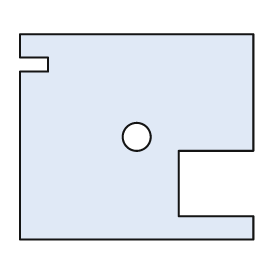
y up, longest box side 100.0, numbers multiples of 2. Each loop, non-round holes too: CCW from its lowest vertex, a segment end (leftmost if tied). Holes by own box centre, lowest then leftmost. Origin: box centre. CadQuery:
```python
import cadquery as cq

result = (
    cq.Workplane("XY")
    .moveTo(-50.0, -44.0)
    .lineTo(50.0, -44.0)
    .lineTo(50.0, -34.0)
    .lineTo(18.0, -34.0)
    .lineTo(18.0, -6.0)
    .lineTo(50.0, -6.0)
    .lineTo(50.0, 44.0)
    .lineTo(-50.0, 44.0)
    .lineTo(-50.0, 34.0)
    .lineTo(-38.0, 34.0)
    .lineTo(-38.0, 28.0)
    .lineTo(-50.0, 28.0)
    .close()
    .moveTo(0.0, 0.0)
    .circle(6.0)
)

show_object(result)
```